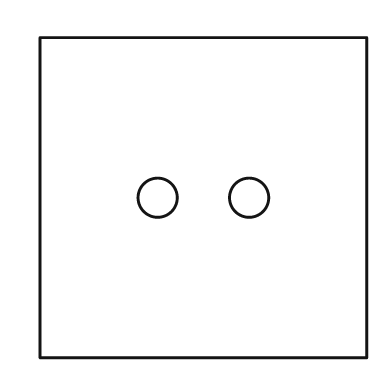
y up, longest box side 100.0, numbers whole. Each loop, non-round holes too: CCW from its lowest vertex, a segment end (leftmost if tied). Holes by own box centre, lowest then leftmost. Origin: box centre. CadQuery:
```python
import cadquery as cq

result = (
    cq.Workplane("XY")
    .moveTo(-50.0, -49.0)
    .lineTo(50.0, -49.0)
    .lineTo(50.0, 49.0)
    .lineTo(-50.0, 49.0)
    .close()
    .moveTo(-14.0, 0.0)
    .circle(6.0)
    .moveTo(14.0, 0.0)
    .circle(6.0)
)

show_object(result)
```